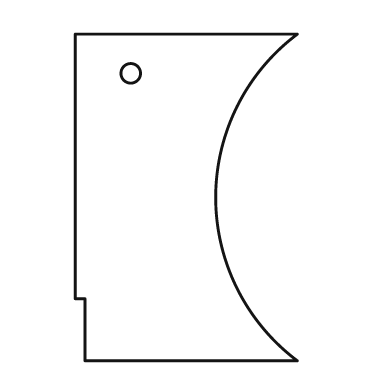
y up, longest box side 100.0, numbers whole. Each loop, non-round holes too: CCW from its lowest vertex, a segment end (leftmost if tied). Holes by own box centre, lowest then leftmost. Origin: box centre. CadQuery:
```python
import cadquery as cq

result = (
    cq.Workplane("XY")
    .moveTo(-31.0, -50.0)
    .lineTo(34.0, -50.0)
    .threePointArc((9.0, 0.0), (34.0, 50.0))
    .lineTo(-34.0, 50.0)
    .lineTo(-34.0, -31.0)
    .lineTo(-31.0, -31.0)
    .close()
    .moveTo(-17.0, 38.0)
    .circle(3.0)
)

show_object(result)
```